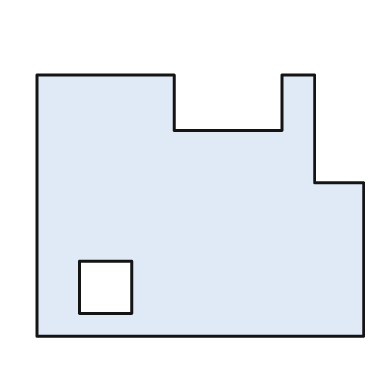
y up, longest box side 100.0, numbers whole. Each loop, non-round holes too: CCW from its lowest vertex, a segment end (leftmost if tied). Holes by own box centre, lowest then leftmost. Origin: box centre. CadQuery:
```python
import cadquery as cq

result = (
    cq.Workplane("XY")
    .moveTo(-50.0, -40.0)
    .lineTo(50.0, -40.0)
    .lineTo(50.0, 7.0)
    .lineTo(35.0, 7.0)
    .lineTo(35.0, 40.0)
    .lineTo(25.0, 40.0)
    .lineTo(25.0, 23.0)
    .lineTo(-8.0, 23.0)
    .lineTo(-8.0, 40.0)
    .lineTo(-50.0, 40.0)
    .close()
    .moveTo(-37.0, -33.0)
    .lineTo(-21.0, -33.0)
    .lineTo(-21.0, -17.0)
    .lineTo(-37.0, -17.0)
    .close()
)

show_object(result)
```